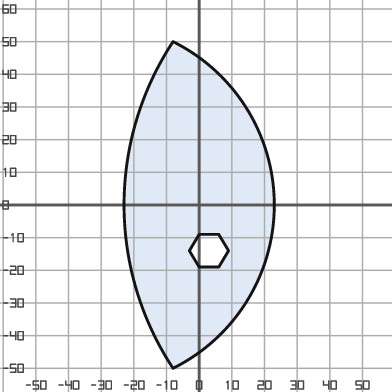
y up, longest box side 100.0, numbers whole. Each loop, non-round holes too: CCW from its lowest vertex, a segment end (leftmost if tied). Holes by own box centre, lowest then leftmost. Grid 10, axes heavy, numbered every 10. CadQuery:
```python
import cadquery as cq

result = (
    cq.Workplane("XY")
    .moveTo(-8.0, -50.0)
    .threePointArc((23.0, 0.0), (-8.0, 50.0))
    .threePointArc((-23.0, 0.0), (-8.0, -50.0))
    .close()
    .moveTo(0.0, -19.0)
    .lineTo(6.0, -19.0)
    .lineTo(9.0, -14.0)
    .lineTo(6.0, -9.0)
    .lineTo(0.0, -9.0)
    .lineTo(-3.0, -14.0)
    .close()
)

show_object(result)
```